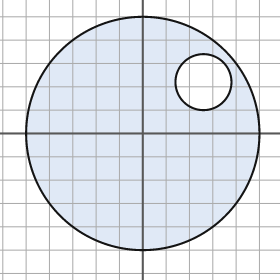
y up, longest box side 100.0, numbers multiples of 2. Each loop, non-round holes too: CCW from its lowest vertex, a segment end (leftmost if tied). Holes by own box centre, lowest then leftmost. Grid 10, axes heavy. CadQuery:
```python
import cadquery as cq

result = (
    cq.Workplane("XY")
    .moveTo(0.0, 0.0)
    .circle(50.0)
    .moveTo(26.0, 22.0)
    .circle(12.0)
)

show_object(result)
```